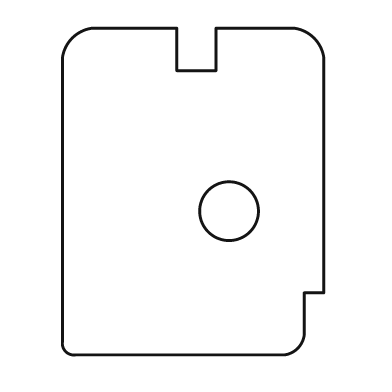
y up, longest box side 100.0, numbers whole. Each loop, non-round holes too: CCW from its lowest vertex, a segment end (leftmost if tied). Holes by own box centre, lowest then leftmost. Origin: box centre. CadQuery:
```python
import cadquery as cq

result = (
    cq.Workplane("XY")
    .moveTo(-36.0, -50.0)
    .lineTo(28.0, -50.0)
    .threePointArc((32.0, -48.0), (34.0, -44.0))
    .lineTo(34.0, -31.0)
    .lineTo(40.0, -31.0)
    .lineTo(40.0, 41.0)
    .threePointArc((37.0, 47.0), (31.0, 50.0))
    .lineTo(7.0, 50.0)
    .lineTo(7.0, 37.0)
    .lineTo(-5.0, 37.0)
    .lineTo(-5.0, 50.0)
    .lineTo(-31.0, 50.0)
    .threePointArc((-37.0, 47.0), (-40.0, 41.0))
    .lineTo(-40.0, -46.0)
    .threePointArc((-39.0, -49.0), (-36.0, -50.0))
    .close()
    .moveTo(11.0, -6.0)
    .circle(9.0)
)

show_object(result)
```